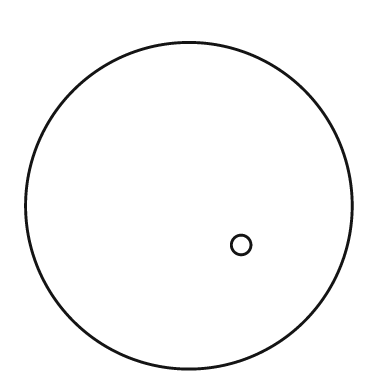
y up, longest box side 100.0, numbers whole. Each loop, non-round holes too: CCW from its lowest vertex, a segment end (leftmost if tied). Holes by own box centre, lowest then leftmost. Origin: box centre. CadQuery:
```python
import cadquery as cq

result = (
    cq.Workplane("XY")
    .moveTo(0.0, 0.0)
    .circle(50.0)
    .moveTo(16.0, -12.0)
    .circle(3.0)
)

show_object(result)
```